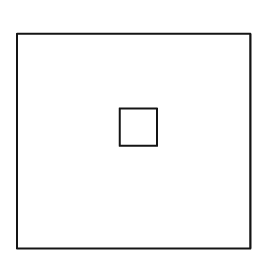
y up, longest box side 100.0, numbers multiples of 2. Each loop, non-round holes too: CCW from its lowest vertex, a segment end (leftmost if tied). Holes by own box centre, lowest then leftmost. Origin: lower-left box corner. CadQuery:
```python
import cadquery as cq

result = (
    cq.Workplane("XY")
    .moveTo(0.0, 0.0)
    .lineTo(100.0, 0.0)
    .lineTo(100.0, 92.0)
    .lineTo(0.0, 92.0)
    .close()
    .moveTo(44.0, 44.0)
    .lineTo(60.0, 44.0)
    .lineTo(60.0, 60.0)
    .lineTo(44.0, 60.0)
    .close()
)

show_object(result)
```